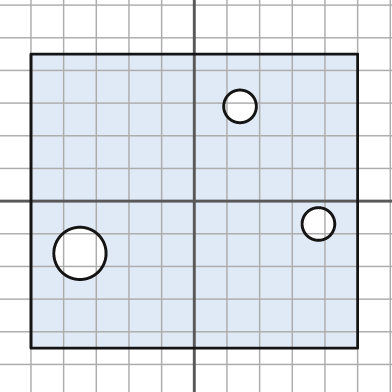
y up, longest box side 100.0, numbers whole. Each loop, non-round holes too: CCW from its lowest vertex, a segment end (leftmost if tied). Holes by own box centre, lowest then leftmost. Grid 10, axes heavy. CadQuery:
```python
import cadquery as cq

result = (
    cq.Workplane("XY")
    .moveTo(-50.0, -45.0)
    .lineTo(50.0, -45.0)
    .lineTo(50.0, 45.0)
    .lineTo(-50.0, 45.0)
    .close()
    .moveTo(-35.0, -16.0)
    .circle(8.0)
    .moveTo(38.0, -7.0)
    .circle(5.0)
    .moveTo(14.0, 29.0)
    .circle(5.0)
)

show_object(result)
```